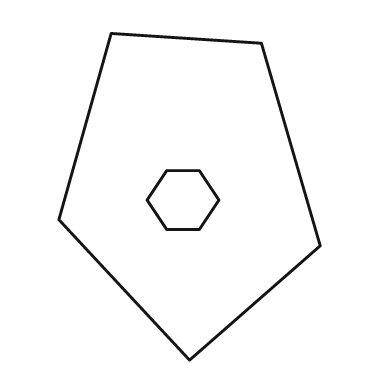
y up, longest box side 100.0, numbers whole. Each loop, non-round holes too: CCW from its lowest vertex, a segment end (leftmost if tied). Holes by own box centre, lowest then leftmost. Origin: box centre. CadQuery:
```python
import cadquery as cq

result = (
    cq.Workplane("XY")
    .moveTo(0.0, -50.0)
    .lineTo(40.0, -15.0)
    .lineTo(22.0, 47.0)
    .lineTo(-24.0, 50.0)
    .lineTo(-40.0, -7.0)
    .close()
    .moveTo(-7.0, -10.0)
    .lineTo(3.0, -10.0)
    .lineTo(9.0, -1.0)
    .lineTo(3.0, 8.0)
    .lineTo(-7.0, 8.0)
    .lineTo(-13.0, -1.0)
    .close()
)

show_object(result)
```